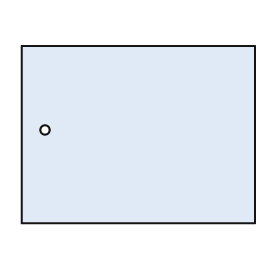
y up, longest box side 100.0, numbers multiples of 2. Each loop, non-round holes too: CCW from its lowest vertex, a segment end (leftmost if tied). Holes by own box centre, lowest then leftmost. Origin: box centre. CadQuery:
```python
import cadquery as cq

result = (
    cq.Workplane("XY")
    .moveTo(-50.0, -38.0)
    .lineTo(50.0, -38.0)
    .lineTo(50.0, 38.0)
    .lineTo(-50.0, 38.0)
    .close()
    .moveTo(-40.0, 2.0)
    .circle(2.0)
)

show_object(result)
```